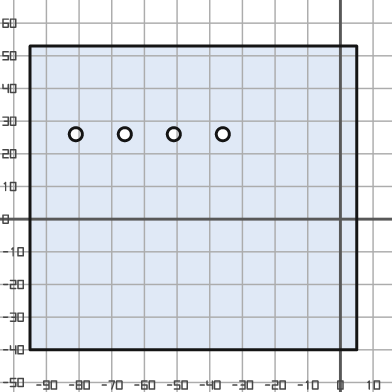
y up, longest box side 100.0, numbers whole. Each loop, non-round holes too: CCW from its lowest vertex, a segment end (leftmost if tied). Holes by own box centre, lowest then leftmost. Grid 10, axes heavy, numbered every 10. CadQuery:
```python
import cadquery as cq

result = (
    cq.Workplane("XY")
    .moveTo(-95.0, -40.0)
    .lineTo(5.0, -40.0)
    .lineTo(5.0, 53.0)
    .lineTo(-95.0, 53.0)
    .close()
    .moveTo(-81.0, 26.0)
    .circle(2.0)
    .moveTo(-66.0, 26.0)
    .circle(2.0)
    .moveTo(-51.0, 26.0)
    .circle(2.0)
    .moveTo(-36.0, 26.0)
    .circle(2.0)
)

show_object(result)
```